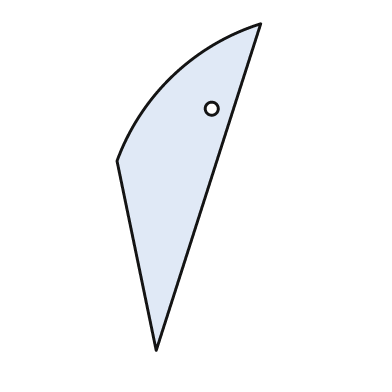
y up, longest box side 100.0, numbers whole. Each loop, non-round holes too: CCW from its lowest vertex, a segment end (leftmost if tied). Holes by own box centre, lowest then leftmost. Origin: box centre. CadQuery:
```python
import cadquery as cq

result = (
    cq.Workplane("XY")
    .moveTo(-10.0, -50.0)
    .lineTo(22.0, 50.0)
    .threePointArc((-5.0, 34.0), (-22.0, 8.0))
    .close()
    .moveTo(7.0, 24.0)
    .circle(2.0)
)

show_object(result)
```